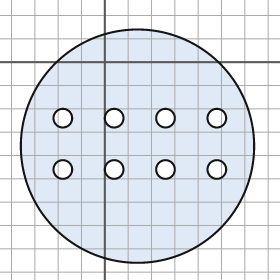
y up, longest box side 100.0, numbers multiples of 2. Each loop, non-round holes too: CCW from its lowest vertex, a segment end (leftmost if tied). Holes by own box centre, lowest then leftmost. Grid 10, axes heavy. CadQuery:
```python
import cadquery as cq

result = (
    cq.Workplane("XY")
    .moveTo(14.0, -36.0)
    .circle(50.0)
    .moveTo(-18.0, -46.0)
    .circle(4.0)
    .moveTo(4.0, -46.0)
    .circle(4.0)
    .moveTo(26.0, -46.0)
    .circle(4.0)
    .moveTo(48.0, -46.0)
    .circle(4.0)
    .moveTo(-18.0, -24.0)
    .circle(4.0)
    .moveTo(4.0, -24.0)
    .circle(4.0)
    .moveTo(26.0, -24.0)
    .circle(4.0)
    .moveTo(48.0, -24.0)
    .circle(4.0)
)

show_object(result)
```